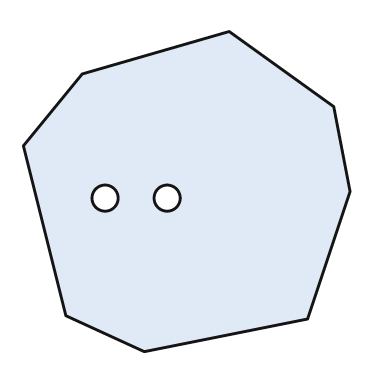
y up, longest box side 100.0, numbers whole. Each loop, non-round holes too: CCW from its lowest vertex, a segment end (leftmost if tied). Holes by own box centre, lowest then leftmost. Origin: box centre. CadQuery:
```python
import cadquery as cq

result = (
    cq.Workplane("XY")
    .moveTo(-13.0, -49.0)
    .lineTo(37.0, -39.0)
    .lineTo(50.0, 0.0)
    .lineTo(45.0, 26.0)
    .lineTo(13.0, 49.0)
    .lineTo(-32.0, 36.0)
    .lineTo(-50.0, 14.0)
    .lineTo(-37.0, -38.0)
    .close()
    .moveTo(-25.0, -2.0)
    .circle(4.0)
    .moveTo(-6.0, -2.0)
    .circle(4.0)
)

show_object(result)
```